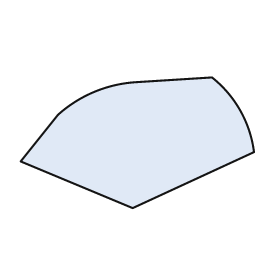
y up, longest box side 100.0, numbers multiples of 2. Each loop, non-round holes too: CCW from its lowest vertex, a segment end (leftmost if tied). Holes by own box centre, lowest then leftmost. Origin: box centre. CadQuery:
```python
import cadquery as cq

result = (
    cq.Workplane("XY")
    .moveTo(-2.0, -28.0)
    .lineTo(50.0, -4.0)
    .threePointArc((44.0, 14.0), (32.0, 28.0))
    .lineTo(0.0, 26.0)
    .threePointArc((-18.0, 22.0), (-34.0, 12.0))
    .lineTo(-50.0, -8.0)
    .close()
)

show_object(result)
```